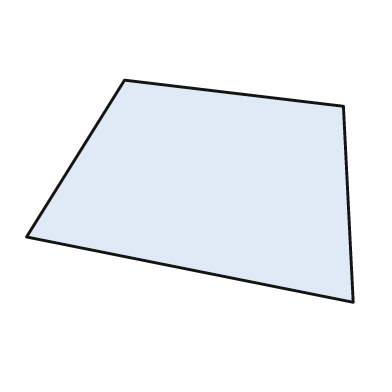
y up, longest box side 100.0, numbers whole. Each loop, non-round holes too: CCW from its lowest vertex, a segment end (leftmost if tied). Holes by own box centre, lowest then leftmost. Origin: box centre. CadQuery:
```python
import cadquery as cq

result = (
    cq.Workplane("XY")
    .moveTo(50.0, -34.0)
    .lineTo(47.0, 26.0)
    .lineTo(-20.0, 34.0)
    .lineTo(-50.0, -14.0)
    .close()
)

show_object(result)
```